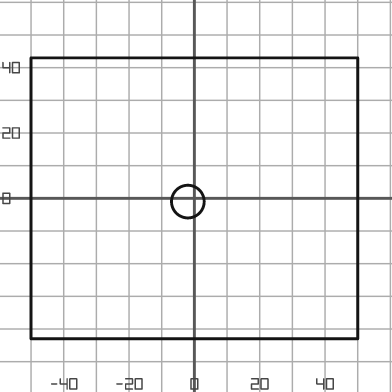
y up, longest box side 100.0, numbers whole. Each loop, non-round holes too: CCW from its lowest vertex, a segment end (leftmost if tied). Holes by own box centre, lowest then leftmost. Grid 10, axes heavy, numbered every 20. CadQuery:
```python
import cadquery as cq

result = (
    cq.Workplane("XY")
    .moveTo(-50.0, -43.0)
    .lineTo(50.0, -43.0)
    .lineTo(50.0, 43.0)
    .lineTo(-50.0, 43.0)
    .close()
    .moveTo(-2.0, -1.0)
    .circle(5.0)
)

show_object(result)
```